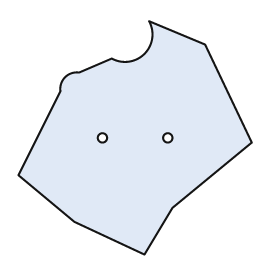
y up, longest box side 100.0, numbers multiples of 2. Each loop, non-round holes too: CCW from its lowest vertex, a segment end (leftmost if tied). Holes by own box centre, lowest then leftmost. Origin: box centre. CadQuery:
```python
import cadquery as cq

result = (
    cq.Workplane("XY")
    .moveTo(4.0, -50.0)
    .lineTo(16.0, -30.0)
    .lineTo(50.0, -2.0)
    .lineTo(30.0, 40.0)
    .lineTo(6.0, 50.0)
    .threePointArc((4.0, 36.0), (-10.0, 34.0))
    .lineTo(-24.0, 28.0)
    .threePointArc((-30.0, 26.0), (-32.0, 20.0))
    .lineTo(-50.0, -16.0)
    .lineTo(-26.0, -36.0)
    .close()
    .moveTo(-14.0, 0.0)
    .circle(2.0)
    .moveTo(14.0, 0.0)
    .circle(2.0)
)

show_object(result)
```